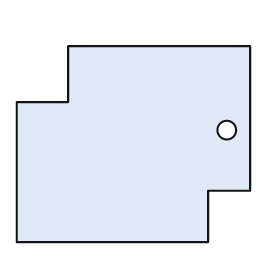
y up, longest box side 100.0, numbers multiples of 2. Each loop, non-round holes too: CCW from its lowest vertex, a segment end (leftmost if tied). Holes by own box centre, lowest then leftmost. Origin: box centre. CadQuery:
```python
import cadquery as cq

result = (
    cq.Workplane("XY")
    .moveTo(-50.0, -42.0)
    .lineTo(32.0, -42.0)
    .lineTo(32.0, -20.0)
    .lineTo(50.0, -20.0)
    .lineTo(50.0, 42.0)
    .lineTo(-28.0, 42.0)
    .lineTo(-28.0, 18.0)
    .lineTo(-50.0, 18.0)
    .close()
    .moveTo(40.0, 6.0)
    .circle(4.0)
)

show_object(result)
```